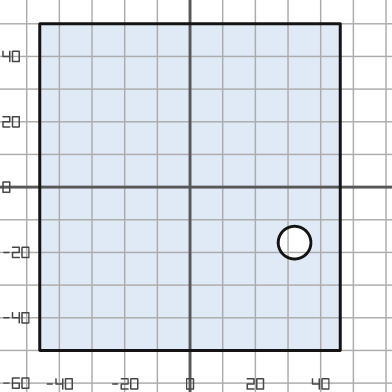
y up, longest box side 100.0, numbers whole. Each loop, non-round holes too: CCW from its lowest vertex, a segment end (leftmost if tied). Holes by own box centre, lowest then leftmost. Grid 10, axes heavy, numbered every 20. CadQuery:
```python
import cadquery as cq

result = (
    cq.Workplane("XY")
    .moveTo(-46.0, -50.0)
    .lineTo(46.0, -50.0)
    .lineTo(46.0, 50.0)
    .lineTo(-46.0, 50.0)
    .close()
    .moveTo(32.0, -17.0)
    .circle(5.0)
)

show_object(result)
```